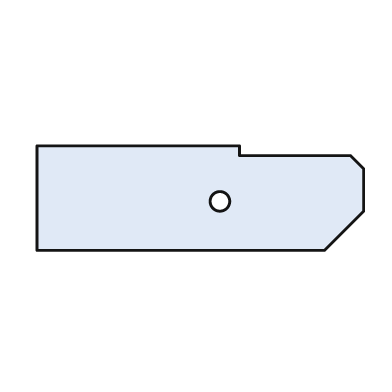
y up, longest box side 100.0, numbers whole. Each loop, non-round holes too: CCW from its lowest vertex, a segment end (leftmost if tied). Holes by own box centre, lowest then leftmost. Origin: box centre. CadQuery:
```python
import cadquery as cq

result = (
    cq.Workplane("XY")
    .moveTo(-50.0, -16.0)
    .lineTo(38.0, -16.0)
    .lineTo(50.0, -4.0)
    .lineTo(50.0, 9.0)
    .lineTo(46.0, 13.0)
    .lineTo(12.0, 13.0)
    .lineTo(12.0, 16.0)
    .lineTo(-50.0, 16.0)
    .close()
    .moveTo(6.0, -1.0)
    .circle(3.0)
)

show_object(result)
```